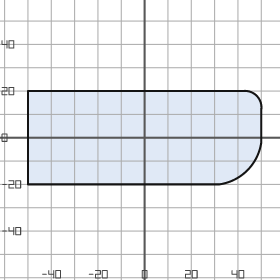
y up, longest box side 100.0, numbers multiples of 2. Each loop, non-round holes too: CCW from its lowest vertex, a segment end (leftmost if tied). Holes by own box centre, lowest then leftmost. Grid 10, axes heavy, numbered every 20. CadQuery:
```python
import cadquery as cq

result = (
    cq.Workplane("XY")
    .moveTo(-50.0, -20.0)
    .lineTo(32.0, -20.0)
    .threePointArc((44.0, -14.0), (50.0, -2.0))
    .lineTo(50.0, 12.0)
    .threePointArc((48.0, 18.0), (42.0, 20.0))
    .lineTo(-50.0, 20.0)
    .close()
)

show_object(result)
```